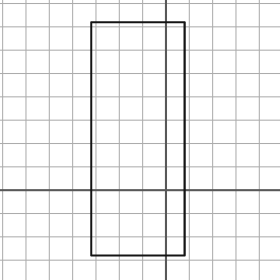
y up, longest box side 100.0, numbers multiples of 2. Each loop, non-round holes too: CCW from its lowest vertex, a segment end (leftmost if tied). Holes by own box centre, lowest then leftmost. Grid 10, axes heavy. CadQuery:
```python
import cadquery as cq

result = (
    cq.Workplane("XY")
    .moveTo(-32.0, -28.0)
    .lineTo(8.0, -28.0)
    .lineTo(8.0, 72.0)
    .lineTo(-32.0, 72.0)
    .close()
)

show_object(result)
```